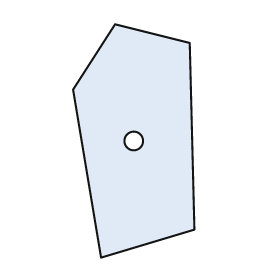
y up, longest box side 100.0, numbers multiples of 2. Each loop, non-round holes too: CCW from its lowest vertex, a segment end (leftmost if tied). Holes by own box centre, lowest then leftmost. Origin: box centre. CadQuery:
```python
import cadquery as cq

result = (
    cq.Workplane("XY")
    .moveTo(-14.0, -50.0)
    .lineTo(26.0, -38.0)
    .lineTo(24.0, 42.0)
    .lineTo(-8.0, 50.0)
    .lineTo(-26.0, 22.0)
    .close()
    .moveTo(0.0, 0.0)
    .circle(4.0)
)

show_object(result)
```